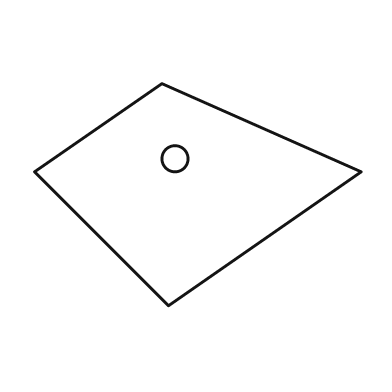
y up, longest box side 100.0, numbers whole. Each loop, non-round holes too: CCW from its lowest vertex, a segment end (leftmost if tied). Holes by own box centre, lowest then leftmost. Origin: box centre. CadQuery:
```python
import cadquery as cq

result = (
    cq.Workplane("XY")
    .moveTo(-9.0, -34.0)
    .lineTo(50.0, 7.0)
    .lineTo(-11.0, 34.0)
    .lineTo(-50.0, 7.0)
    .close()
    .moveTo(-7.0, 11.0)
    .circle(4.0)
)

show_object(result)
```